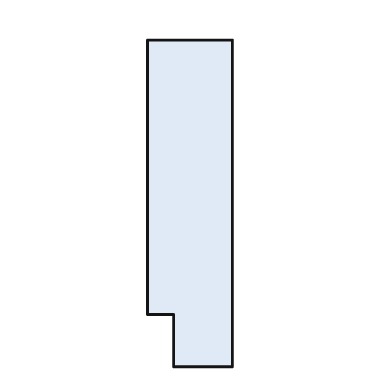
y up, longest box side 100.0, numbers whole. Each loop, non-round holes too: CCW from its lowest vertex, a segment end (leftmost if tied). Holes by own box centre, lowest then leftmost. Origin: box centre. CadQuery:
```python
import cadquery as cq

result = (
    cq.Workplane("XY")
    .moveTo(-5.0, -50.0)
    .lineTo(13.0, -50.0)
    .lineTo(13.0, 50.0)
    .lineTo(-13.0, 50.0)
    .lineTo(-13.0, -34.0)
    .lineTo(-5.0, -34.0)
    .close()
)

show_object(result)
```